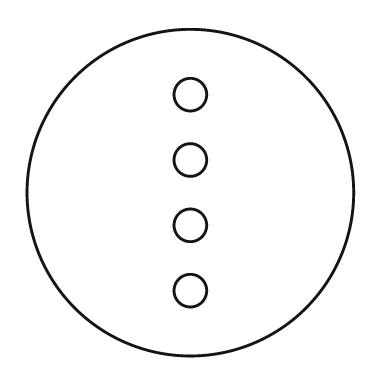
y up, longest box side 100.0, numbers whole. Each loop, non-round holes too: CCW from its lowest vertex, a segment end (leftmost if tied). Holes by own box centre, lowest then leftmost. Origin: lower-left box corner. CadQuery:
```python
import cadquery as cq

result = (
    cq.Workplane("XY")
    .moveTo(50.0, 50.0)
    .circle(50.0)
    .moveTo(50.0, 20.0)
    .circle(5.0)
    .moveTo(50.0, 40.0)
    .circle(5.0)
    .moveTo(50.0, 60.0)
    .circle(5.0)
    .moveTo(50.0, 80.0)
    .circle(5.0)
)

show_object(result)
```